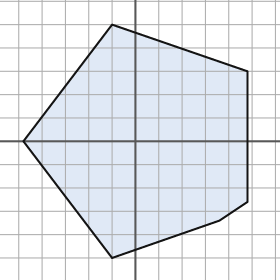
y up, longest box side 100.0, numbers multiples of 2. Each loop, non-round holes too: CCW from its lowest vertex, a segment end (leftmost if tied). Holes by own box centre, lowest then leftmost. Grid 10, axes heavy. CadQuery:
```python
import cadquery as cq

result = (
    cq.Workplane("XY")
    .moveTo(-10.0, -50.0)
    .lineTo(36.0, -34.0)
    .lineTo(48.0, -26.0)
    .lineTo(48.0, 30.0)
    .lineTo(-10.0, 50.0)
    .lineTo(-48.0, 0.0)
    .close()
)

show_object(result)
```